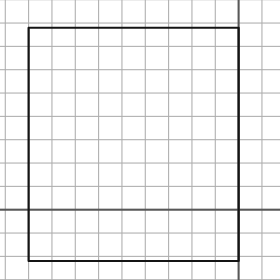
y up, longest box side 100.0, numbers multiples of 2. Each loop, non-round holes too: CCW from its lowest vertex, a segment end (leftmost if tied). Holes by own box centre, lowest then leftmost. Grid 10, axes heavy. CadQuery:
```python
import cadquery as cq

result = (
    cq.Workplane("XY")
    .moveTo(-90.0, -22.0)
    .lineTo(0.0, -22.0)
    .lineTo(0.0, 78.0)
    .lineTo(-90.0, 78.0)
    .close()
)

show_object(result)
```